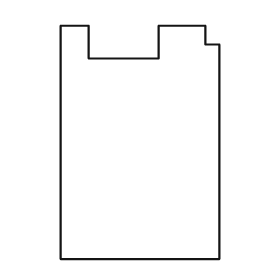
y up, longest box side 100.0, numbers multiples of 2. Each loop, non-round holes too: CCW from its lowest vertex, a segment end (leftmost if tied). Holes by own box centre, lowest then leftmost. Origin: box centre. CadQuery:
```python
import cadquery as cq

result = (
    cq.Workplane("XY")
    .moveTo(-34.0, -50.0)
    .lineTo(34.0, -50.0)
    .lineTo(34.0, 42.0)
    .lineTo(28.0, 42.0)
    .lineTo(28.0, 50.0)
    .lineTo(8.0, 50.0)
    .lineTo(8.0, 36.0)
    .lineTo(-22.0, 36.0)
    .lineTo(-22.0, 50.0)
    .lineTo(-34.0, 50.0)
    .close()
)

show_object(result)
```